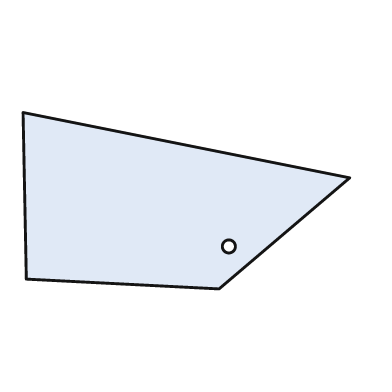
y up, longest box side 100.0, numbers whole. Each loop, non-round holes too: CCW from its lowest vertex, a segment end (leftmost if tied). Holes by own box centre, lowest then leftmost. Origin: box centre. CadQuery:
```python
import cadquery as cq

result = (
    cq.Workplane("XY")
    .moveTo(10.0, -27.0)
    .lineTo(50.0, 7.0)
    .lineTo(-50.0, 27.0)
    .lineTo(-49.0, -24.0)
    .close()
    .moveTo(13.0, -14.0)
    .circle(2.0)
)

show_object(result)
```